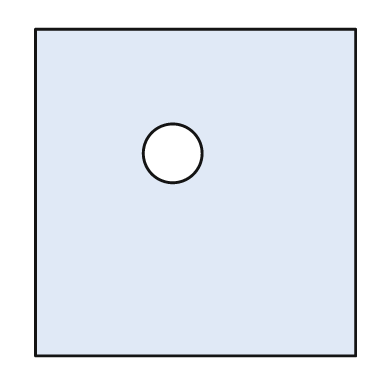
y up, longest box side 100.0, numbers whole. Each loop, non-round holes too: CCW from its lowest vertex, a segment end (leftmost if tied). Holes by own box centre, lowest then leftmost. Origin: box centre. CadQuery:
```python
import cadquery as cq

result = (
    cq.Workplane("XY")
    .moveTo(-49.0, -50.0)
    .lineTo(49.0, -50.0)
    .lineTo(49.0, 50.0)
    .lineTo(-49.0, 50.0)
    .close()
    .moveTo(-7.0, 12.0)
    .circle(9.0)
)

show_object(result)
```